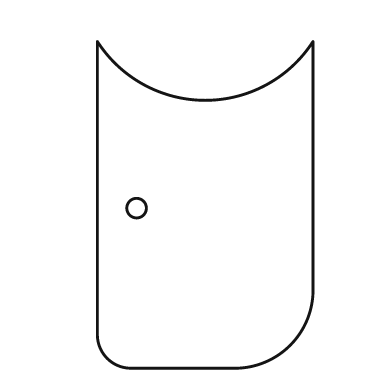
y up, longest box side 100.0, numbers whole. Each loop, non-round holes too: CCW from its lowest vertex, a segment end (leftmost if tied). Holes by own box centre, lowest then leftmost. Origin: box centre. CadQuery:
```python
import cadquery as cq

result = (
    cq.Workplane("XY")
    .moveTo(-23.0, -50.0)
    .lineTo(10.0, -50.0)
    .threePointArc((26.0, -43.0), (33.0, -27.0))
    .lineTo(33.0, 50.0)
    .threePointArc((0.0, 32.0), (-33.0, 50.0))
    .lineTo(-33.0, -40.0)
    .threePointArc((-30.0, -47.0), (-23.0, -50.0))
    .close()
    .moveTo(-21.0, -1.0)
    .circle(3.0)
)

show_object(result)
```